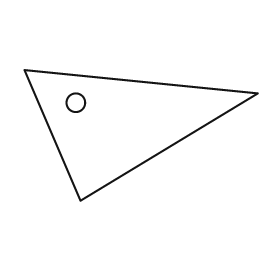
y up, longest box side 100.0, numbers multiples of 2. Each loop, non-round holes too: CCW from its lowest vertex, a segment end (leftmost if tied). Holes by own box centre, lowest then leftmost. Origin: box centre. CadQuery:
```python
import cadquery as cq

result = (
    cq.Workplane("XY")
    .moveTo(-26.0, -28.0)
    .lineTo(50.0, 18.0)
    .lineTo(-50.0, 28.0)
    .close()
    .moveTo(-28.0, 14.0)
    .circle(4.0)
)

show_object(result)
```